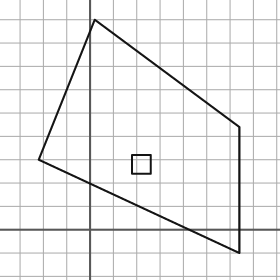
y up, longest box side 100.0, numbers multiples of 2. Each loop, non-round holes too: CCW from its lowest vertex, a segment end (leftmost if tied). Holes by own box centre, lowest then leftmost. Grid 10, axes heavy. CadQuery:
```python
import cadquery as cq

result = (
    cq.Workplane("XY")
    .moveTo(64.0, -10.0)
    .lineTo(64.0, 44.0)
    .lineTo(2.0, 90.0)
    .lineTo(-22.0, 30.0)
    .close()
    .moveTo(18.0, 24.0)
    .lineTo(26.0, 24.0)
    .lineTo(26.0, 32.0)
    .lineTo(18.0, 32.0)
    .close()
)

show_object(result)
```